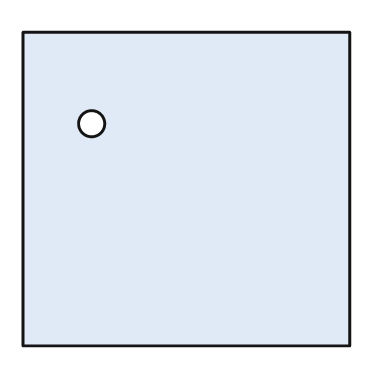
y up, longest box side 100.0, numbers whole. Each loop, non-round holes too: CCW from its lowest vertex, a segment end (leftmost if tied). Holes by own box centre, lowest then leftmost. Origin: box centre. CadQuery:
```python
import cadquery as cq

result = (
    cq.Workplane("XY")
    .moveTo(-50.0, -48.0)
    .lineTo(50.0, -48.0)
    .lineTo(50.0, 48.0)
    .lineTo(-50.0, 48.0)
    .close()
    .moveTo(-29.0, 20.0)
    .circle(4.0)
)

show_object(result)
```